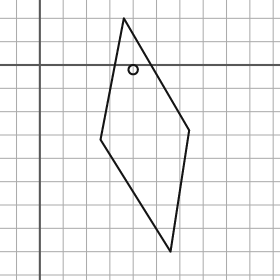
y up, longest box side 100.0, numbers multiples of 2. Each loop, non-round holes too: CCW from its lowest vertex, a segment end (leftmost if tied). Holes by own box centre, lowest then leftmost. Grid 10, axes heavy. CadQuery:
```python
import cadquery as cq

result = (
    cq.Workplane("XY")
    .moveTo(56.0, -80.0)
    .lineTo(64.0, -28.0)
    .lineTo(36.0, 20.0)
    .lineTo(26.0, -32.0)
    .close()
    .moveTo(40.0, -2.0)
    .circle(2.0)
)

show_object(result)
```